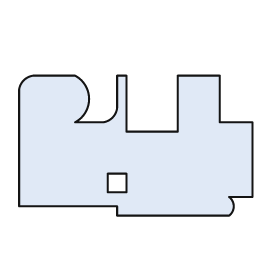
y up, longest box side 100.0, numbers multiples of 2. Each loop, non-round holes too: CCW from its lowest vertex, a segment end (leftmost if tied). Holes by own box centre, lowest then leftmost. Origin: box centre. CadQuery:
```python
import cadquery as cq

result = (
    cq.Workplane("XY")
    .moveTo(-8.0, -30.0)
    .lineTo(40.0, -30.0)
    .threePointArc((42.0, -26.0), (40.0, -22.0))
    .lineTo(50.0, -22.0)
    .lineTo(50.0, 10.0)
    .lineTo(36.0, 10.0)
    .lineTo(36.0, 30.0)
    .lineTo(18.0, 30.0)
    .lineTo(18.0, 6.0)
    .lineTo(-4.0, 6.0)
    .lineTo(-4.0, 30.0)
    .lineTo(-8.0, 30.0)
    .lineTo(-8.0, 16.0)
    .threePointArc((-10.0, 12.0), (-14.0, 10.0))
    .lineTo(-26.0, 10.0)
    .threePointArc((-20.0, 20.0), (-26.0, 30.0))
    .lineTo(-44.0, 30.0)
    .threePointArc((-48.0, 28.0), (-50.0, 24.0))
    .lineTo(-50.0, -26.0)
    .lineTo(-8.0, -26.0)
    .close()
    .moveTo(-12.0, -20.0)
    .lineTo(-4.0, -20.0)
    .lineTo(-4.0, -12.0)
    .lineTo(-12.0, -12.0)
    .close()
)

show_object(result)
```